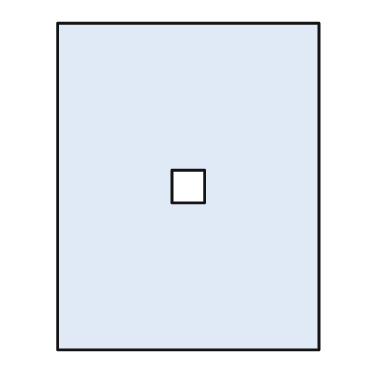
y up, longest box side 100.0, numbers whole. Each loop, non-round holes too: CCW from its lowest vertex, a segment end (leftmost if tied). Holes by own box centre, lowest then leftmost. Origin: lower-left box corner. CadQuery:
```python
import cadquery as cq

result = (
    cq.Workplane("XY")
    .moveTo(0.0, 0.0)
    .lineTo(80.0, 0.0)
    .lineTo(80.0, 100.0)
    .lineTo(0.0, 100.0)
    .close()
    .moveTo(35.0, 45.0)
    .lineTo(45.0, 45.0)
    .lineTo(45.0, 55.0)
    .lineTo(35.0, 55.0)
    .close()
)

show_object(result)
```